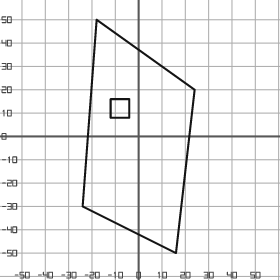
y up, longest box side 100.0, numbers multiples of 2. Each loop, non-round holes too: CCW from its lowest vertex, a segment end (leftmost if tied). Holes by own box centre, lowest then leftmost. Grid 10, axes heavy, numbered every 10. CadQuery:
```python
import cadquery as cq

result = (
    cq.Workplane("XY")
    .moveTo(16.0, -50.0)
    .lineTo(24.0, 20.0)
    .lineTo(-18.0, 50.0)
    .lineTo(-24.0, -30.0)
    .close()
    .moveTo(-12.0, 8.0)
    .lineTo(-4.0, 8.0)
    .lineTo(-4.0, 16.0)
    .lineTo(-12.0, 16.0)
    .close()
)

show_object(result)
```